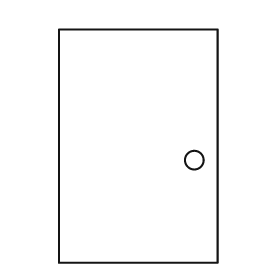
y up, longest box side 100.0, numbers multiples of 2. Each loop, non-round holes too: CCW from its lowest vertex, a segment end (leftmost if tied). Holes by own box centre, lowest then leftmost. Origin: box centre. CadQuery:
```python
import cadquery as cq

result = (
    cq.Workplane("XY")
    .moveTo(-34.0, -50.0)
    .lineTo(34.0, -50.0)
    .lineTo(34.0, 50.0)
    .lineTo(-34.0, 50.0)
    .close()
    .moveTo(24.0, -6.0)
    .circle(4.0)
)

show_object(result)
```